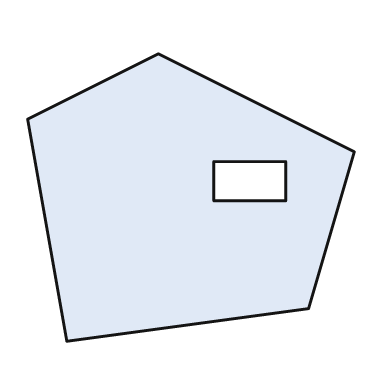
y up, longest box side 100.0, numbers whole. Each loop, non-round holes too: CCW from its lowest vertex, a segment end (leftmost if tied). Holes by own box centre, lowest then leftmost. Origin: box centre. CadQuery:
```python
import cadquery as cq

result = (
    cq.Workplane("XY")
    .moveTo(-38.0, -44.0)
    .lineTo(36.0, -34.0)
    .lineTo(50.0, 14.0)
    .lineTo(-10.0, 44.0)
    .lineTo(-50.0, 24.0)
    .close()
    .moveTo(7.0, -1.0)
    .lineTo(29.0, -1.0)
    .lineTo(29.0, 11.0)
    .lineTo(7.0, 11.0)
    .close()
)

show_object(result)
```